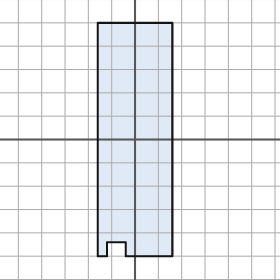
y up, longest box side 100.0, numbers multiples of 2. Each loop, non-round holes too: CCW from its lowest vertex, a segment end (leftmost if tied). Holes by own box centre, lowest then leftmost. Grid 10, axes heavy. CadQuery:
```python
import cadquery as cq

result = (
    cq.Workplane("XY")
    .moveTo(-16.0, -50.0)
    .lineTo(-12.0, -50.0)
    .lineTo(-12.0, -44.0)
    .lineTo(-4.0, -44.0)
    .lineTo(-4.0, -50.0)
    .lineTo(16.0, -50.0)
    .lineTo(16.0, 50.0)
    .lineTo(-16.0, 50.0)
    .close()
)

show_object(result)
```